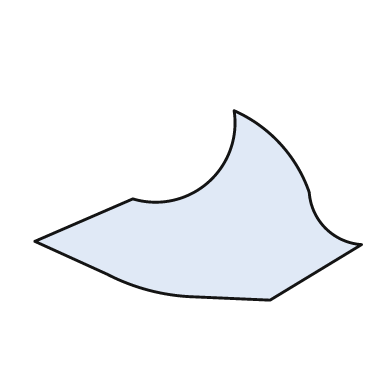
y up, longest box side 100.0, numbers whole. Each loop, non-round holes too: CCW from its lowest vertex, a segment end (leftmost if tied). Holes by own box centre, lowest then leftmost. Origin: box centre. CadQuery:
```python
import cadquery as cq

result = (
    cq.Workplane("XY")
    .moveTo(22.0, -29.0)
    .lineTo(50.0, -12.0)
    .threePointArc((39.0, -7.0), (34.0, 4.0))
    .threePointArc((25.0, 19.0), (11.0, 29.0))
    .threePointArc((3.0, 7.0), (-20.0, 2.0))
    .lineTo(-50.0, -11.0)
    .lineTo(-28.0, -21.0)
    .threePointArc((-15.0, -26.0), (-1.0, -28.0))
    .close()
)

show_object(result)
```